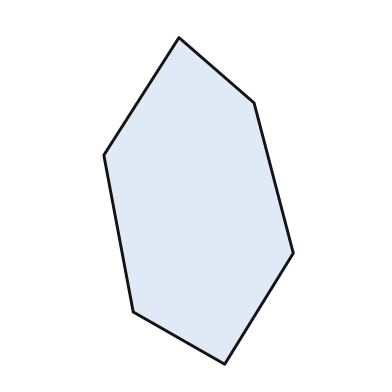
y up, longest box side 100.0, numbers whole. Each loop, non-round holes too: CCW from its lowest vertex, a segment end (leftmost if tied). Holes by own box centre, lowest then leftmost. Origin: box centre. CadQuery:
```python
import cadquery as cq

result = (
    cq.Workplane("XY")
    .moveTo(8.0, -50.0)
    .lineTo(29.0, -16.0)
    .lineTo(17.0, 30.0)
    .lineTo(-6.0, 50.0)
    .lineTo(-29.0, 14.0)
    .lineTo(-20.0, -34.0)
    .close()
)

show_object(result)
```